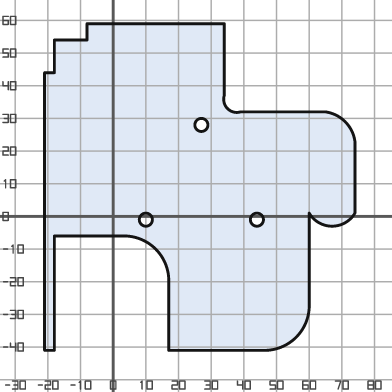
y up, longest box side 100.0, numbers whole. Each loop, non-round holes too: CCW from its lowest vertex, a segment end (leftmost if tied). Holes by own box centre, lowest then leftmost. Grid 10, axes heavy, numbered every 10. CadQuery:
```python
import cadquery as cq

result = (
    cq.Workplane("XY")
    .moveTo(-21.0, -41.0)
    .lineTo(-18.0, -41.0)
    .lineTo(-18.0, -6.0)
    .lineTo(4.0, -6.0)
    .threePointArc((13.0, -10.0), (17.0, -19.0))
    .lineTo(17.0, -41.0)
    .lineTo(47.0, -41.0)
    .threePointArc((56.0, -37.0), (60.0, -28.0))
    .lineTo(60.0, 1.0)
    .threePointArc((67.0, -3.0), (74.0, 1.0))
    .lineTo(74.0, 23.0)
    .threePointArc((71.0, 29.0), (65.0, 32.0))
    .lineTo(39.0, 32.0)
    .threePointArc((35.0, 33.0), (34.0, 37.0))
    .lineTo(34.0, 59.0)
    .lineTo(-8.0, 59.0)
    .lineTo(-8.0, 54.0)
    .lineTo(-18.0, 54.0)
    .lineTo(-18.0, 44.0)
    .lineTo(-21.0, 44.0)
    .close()
    .moveTo(10.0, -1.0)
    .circle(2.0)
    .moveTo(44.0, -1.0)
    .circle(2.0)
    .moveTo(27.0, 28.0)
    .circle(2.0)
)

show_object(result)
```